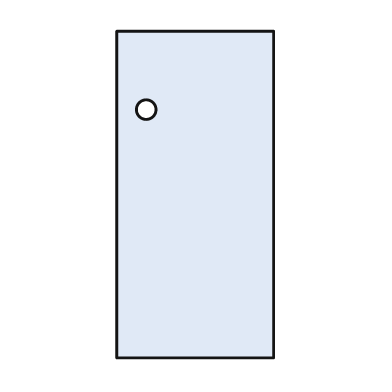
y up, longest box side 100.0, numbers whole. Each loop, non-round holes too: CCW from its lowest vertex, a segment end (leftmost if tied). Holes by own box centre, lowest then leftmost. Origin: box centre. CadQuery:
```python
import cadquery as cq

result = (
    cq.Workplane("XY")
    .moveTo(-24.0, -50.0)
    .lineTo(24.0, -50.0)
    .lineTo(24.0, 50.0)
    .lineTo(-24.0, 50.0)
    .close()
    .moveTo(-15.0, 26.0)
    .circle(3.0)
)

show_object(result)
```